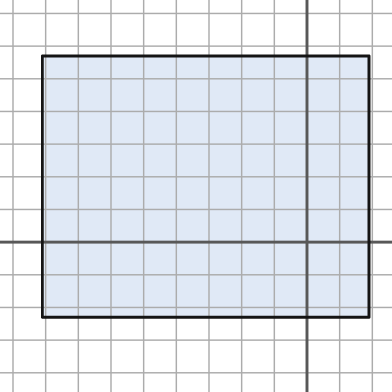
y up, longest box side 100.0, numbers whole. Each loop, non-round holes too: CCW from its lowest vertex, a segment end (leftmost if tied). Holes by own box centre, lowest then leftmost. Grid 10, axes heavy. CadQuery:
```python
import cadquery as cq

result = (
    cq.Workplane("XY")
    .moveTo(-81.0, -23.0)
    .lineTo(19.0, -23.0)
    .lineTo(19.0, 57.0)
    .lineTo(-81.0, 57.0)
    .close()
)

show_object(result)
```